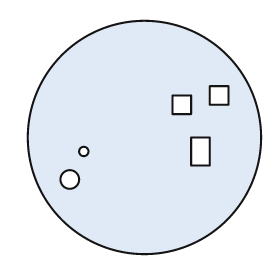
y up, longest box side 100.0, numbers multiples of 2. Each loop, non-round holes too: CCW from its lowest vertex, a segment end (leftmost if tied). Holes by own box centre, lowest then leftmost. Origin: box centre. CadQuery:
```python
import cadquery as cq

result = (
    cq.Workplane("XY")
    .moveTo(0.0, 0.0)
    .circle(50.0)
    .moveTo(-32.0, -18.0)
    .circle(4.0)
    .moveTo(-26.0, -6.0)
    .circle(2.0)
    .moveTo(20.0, -12.0)
    .lineTo(28.0, -12.0)
    .lineTo(28.0, 0.0)
    .lineTo(20.0, 0.0)
    .close()
    .moveTo(12.0, 10.0)
    .lineTo(20.0, 10.0)
    .lineTo(20.0, 18.0)
    .lineTo(12.0, 18.0)
    .close()
    .moveTo(28.0, 14.0)
    .lineTo(36.0, 14.0)
    .lineTo(36.0, 22.0)
    .lineTo(28.0, 22.0)
    .close()
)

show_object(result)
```